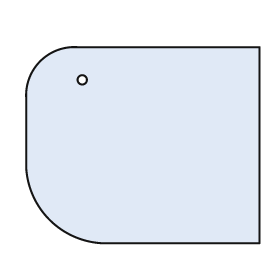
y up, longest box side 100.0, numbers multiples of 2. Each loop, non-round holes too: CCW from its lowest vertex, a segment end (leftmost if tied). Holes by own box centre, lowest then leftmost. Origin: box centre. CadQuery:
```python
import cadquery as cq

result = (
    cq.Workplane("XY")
    .moveTo(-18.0, -42.0)
    .lineTo(50.0, -42.0)
    .lineTo(50.0, 42.0)
    .lineTo(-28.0, 42.0)
    .threePointArc((-44.0, 36.0), (-50.0, 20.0))
    .lineTo(-50.0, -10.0)
    .threePointArc((-40.0, -32.0), (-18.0, -42.0))
    .close()
    .moveTo(-26.0, 28.0)
    .circle(2.0)
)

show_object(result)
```